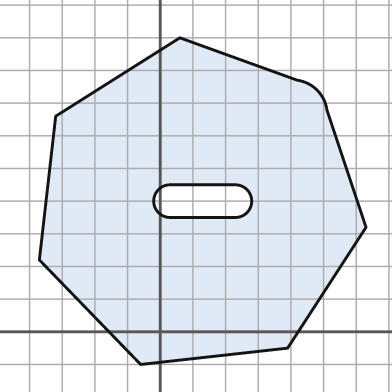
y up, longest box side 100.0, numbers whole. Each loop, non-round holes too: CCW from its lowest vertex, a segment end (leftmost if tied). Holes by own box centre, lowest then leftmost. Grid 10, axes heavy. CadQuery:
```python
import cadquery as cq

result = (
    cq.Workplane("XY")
    .moveTo(-6.0, -10.0)
    .lineTo(39.0, -5.0)
    .lineTo(63.0, 32.0)
    .lineTo(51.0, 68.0)
    .threePointArc((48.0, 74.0), (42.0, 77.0))
    .lineTo(6.0, 90.0)
    .lineTo(-32.0, 66.0)
    .lineTo(-37.0, 22.0)
    .close()
    .moveTo(3.0, 35.0)
    .lineTo(23.0, 35.0)
    .threePointArc((28.0, 40.0), (23.0, 45.0))
    .lineTo(3.0, 45.0)
    .threePointArc((-2.0, 40.0), (3.0, 35.0))
    .close()
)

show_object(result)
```